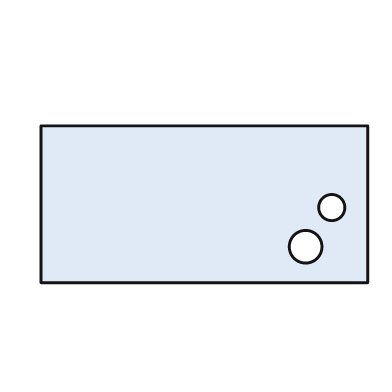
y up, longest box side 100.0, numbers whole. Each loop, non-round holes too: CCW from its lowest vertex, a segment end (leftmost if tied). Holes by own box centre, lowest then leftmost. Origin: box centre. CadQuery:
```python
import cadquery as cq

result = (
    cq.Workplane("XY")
    .moveTo(-50.0, -24.0)
    .lineTo(50.0, -24.0)
    .lineTo(50.0, 24.0)
    .lineTo(-50.0, 24.0)
    .close()
    .moveTo(31.0, -13.0)
    .circle(5.0)
    .moveTo(39.0, -1.0)
    .circle(4.0)
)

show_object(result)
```